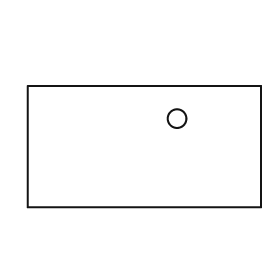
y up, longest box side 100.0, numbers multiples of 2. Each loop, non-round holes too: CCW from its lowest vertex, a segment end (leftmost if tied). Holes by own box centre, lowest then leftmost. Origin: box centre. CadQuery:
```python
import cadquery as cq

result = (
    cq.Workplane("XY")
    .moveTo(-50.0, -26.0)
    .lineTo(50.0, -26.0)
    .lineTo(50.0, 26.0)
    .lineTo(-50.0, 26.0)
    .close()
    .moveTo(14.0, 12.0)
    .circle(4.0)
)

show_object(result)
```